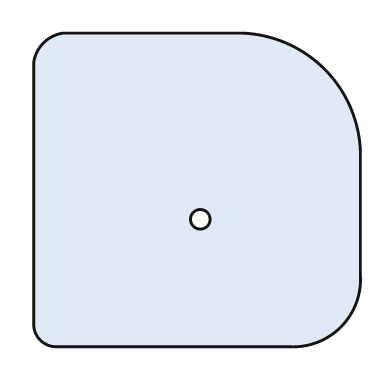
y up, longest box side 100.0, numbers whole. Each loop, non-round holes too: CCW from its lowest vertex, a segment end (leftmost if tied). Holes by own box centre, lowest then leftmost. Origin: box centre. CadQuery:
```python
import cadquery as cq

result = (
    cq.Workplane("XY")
    .moveTo(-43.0, -48.0)
    .lineTo(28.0, -48.0)
    .threePointArc((44.0, -42.0), (50.0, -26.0))
    .lineTo(50.0, 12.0)
    .threePointArc((39.0, 37.0), (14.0, 48.0))
    .lineTo(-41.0, 48.0)
    .threePointArc((-47.0, 45.0), (-50.0, 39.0))
    .lineTo(-50.0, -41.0)
    .threePointArc((-48.0, -46.0), (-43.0, -48.0))
    .close()
    .moveTo(1.0, -9.0)
    .circle(3.0)
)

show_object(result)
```